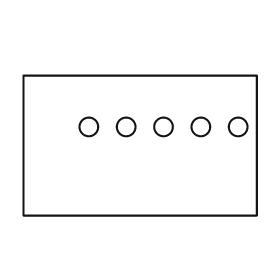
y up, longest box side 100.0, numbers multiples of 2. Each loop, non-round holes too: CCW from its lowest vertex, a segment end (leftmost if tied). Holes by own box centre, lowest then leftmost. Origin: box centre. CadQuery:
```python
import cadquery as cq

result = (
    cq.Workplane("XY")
    .moveTo(-50.0, -30.0)
    .lineTo(50.0, -30.0)
    .lineTo(50.0, 30.0)
    .lineTo(-50.0, 30.0)
    .close()
    .moveTo(-22.0, 8.0)
    .circle(4.0)
    .moveTo(-6.0, 8.0)
    .circle(4.0)
    .moveTo(10.0, 8.0)
    .circle(4.0)
    .moveTo(26.0, 8.0)
    .circle(4.0)
    .moveTo(42.0, 8.0)
    .circle(4.0)
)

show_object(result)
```